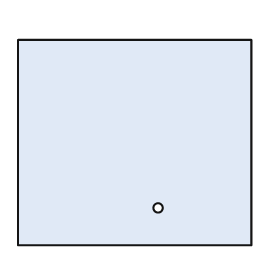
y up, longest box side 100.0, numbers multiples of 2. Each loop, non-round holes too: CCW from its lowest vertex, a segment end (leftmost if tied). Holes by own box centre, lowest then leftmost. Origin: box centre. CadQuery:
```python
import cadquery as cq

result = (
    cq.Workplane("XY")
    .moveTo(-50.0, -44.0)
    .lineTo(50.0, -44.0)
    .lineTo(50.0, 44.0)
    .lineTo(-50.0, 44.0)
    .close()
    .moveTo(10.0, -28.0)
    .circle(2.0)
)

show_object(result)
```